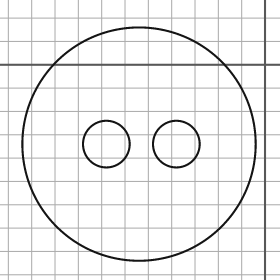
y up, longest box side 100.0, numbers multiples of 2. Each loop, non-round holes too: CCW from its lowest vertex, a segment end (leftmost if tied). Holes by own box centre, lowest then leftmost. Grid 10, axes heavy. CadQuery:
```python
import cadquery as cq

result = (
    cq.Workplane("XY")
    .moveTo(-54.0, -34.0)
    .circle(50.0)
    .moveTo(-68.0, -34.0)
    .circle(10.0)
    .moveTo(-38.0, -34.0)
    .circle(10.0)
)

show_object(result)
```